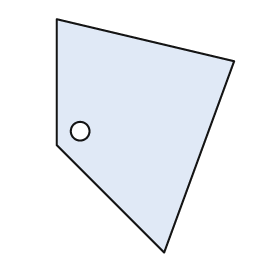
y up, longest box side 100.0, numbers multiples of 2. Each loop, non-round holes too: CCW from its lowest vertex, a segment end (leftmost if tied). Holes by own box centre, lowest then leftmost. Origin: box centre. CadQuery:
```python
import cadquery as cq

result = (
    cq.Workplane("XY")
    .moveTo(8.0, -50.0)
    .lineTo(38.0, 32.0)
    .lineTo(-38.0, 50.0)
    .lineTo(-38.0, -4.0)
    .close()
    .moveTo(-28.0, 2.0)
    .circle(4.0)
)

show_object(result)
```